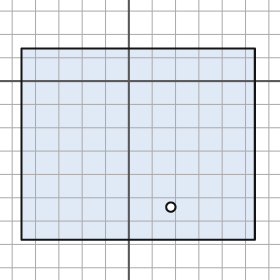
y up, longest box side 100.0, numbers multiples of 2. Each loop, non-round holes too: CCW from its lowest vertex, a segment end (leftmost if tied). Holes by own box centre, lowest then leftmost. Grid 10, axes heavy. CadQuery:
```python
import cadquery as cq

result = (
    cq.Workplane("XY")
    .moveTo(-46.0, -68.0)
    .lineTo(54.0, -68.0)
    .lineTo(54.0, 14.0)
    .lineTo(-46.0, 14.0)
    .close()
    .moveTo(18.0, -54.0)
    .circle(2.0)
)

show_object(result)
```